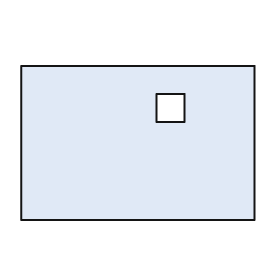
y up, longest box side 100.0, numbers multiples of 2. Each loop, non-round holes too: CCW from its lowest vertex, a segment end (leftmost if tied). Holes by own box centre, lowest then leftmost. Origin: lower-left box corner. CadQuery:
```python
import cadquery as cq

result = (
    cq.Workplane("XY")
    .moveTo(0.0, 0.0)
    .lineTo(100.0, 0.0)
    .lineTo(100.0, 66.0)
    .lineTo(0.0, 66.0)
    .close()
    .moveTo(58.0, 42.0)
    .lineTo(70.0, 42.0)
    .lineTo(70.0, 54.0)
    .lineTo(58.0, 54.0)
    .close()
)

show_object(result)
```